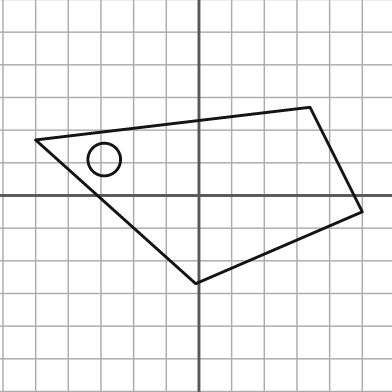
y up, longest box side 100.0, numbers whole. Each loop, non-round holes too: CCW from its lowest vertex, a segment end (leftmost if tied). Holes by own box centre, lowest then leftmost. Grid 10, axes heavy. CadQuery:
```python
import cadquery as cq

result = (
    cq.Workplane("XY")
    .moveTo(-1.0, -27.0)
    .lineTo(50.0, -5.0)
    .lineTo(34.0, 27.0)
    .lineTo(-50.0, 17.0)
    .close()
    .moveTo(-29.0, 11.0)
    .circle(5.0)
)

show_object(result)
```